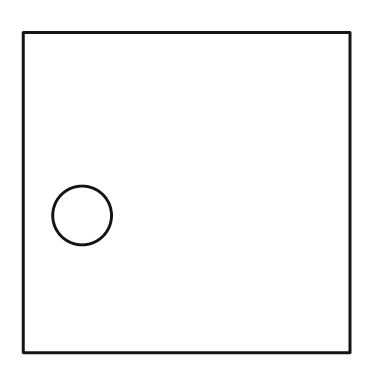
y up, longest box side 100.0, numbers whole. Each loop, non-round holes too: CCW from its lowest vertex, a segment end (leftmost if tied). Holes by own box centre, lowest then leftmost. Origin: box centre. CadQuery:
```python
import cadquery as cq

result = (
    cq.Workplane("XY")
    .moveTo(-50.0, -49.0)
    .lineTo(50.0, -49.0)
    .lineTo(50.0, 49.0)
    .lineTo(-50.0, 49.0)
    .close()
    .moveTo(-32.0, -7.0)
    .circle(9.0)
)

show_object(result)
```